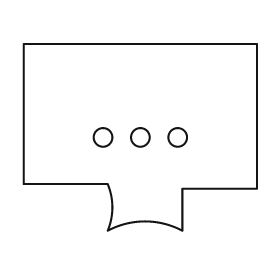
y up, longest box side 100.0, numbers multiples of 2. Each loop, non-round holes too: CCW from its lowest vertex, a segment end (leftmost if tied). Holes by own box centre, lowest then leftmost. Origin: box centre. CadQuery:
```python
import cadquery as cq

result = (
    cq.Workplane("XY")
    .moveTo(-14.0, -40.0)
    .threePointArc((2.0, -36.0), (18.0, -40.0))
    .lineTo(18.0, -22.0)
    .lineTo(50.0, -22.0)
    .lineTo(50.0, 40.0)
    .lineTo(-50.0, 40.0)
    .lineTo(-50.0, -20.0)
    .lineTo(-14.0, -20.0)
    .threePointArc((-12.0, -30.0), (-14.0, -40.0))
    .close()
    .moveTo(-16.0, 0.0)
    .circle(4.0)
    .moveTo(0.0, 0.0)
    .circle(4.0)
    .moveTo(16.0, 0.0)
    .circle(4.0)
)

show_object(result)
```